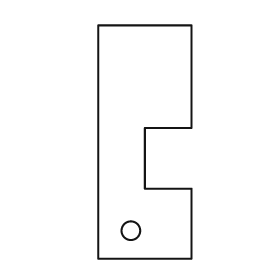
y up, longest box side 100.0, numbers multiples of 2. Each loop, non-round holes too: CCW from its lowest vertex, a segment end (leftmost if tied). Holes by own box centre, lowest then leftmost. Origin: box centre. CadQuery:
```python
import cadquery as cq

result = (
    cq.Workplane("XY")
    .moveTo(-20.0, -50.0)
    .lineTo(20.0, -50.0)
    .lineTo(20.0, -20.0)
    .lineTo(0.0, -20.0)
    .lineTo(0.0, 6.0)
    .lineTo(20.0, 6.0)
    .lineTo(20.0, 50.0)
    .lineTo(-20.0, 50.0)
    .close()
    .moveTo(-6.0, -38.0)
    .circle(4.0)
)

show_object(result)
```